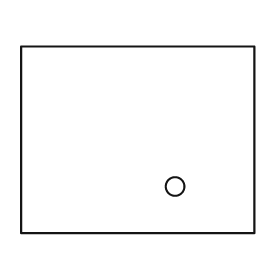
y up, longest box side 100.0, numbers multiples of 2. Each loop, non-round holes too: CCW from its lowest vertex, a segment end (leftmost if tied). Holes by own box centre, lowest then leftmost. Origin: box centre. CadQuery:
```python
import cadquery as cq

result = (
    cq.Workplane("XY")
    .moveTo(-50.0, -40.0)
    .lineTo(50.0, -40.0)
    .lineTo(50.0, 40.0)
    .lineTo(-50.0, 40.0)
    .close()
    .moveTo(16.0, -20.0)
    .circle(4.0)
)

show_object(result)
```